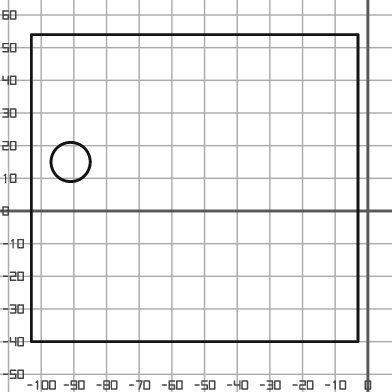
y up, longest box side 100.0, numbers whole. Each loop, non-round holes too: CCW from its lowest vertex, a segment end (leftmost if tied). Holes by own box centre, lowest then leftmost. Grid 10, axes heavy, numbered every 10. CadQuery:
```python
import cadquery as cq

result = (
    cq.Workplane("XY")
    .moveTo(-103.0, -40.0)
    .lineTo(-3.0, -40.0)
    .lineTo(-3.0, 54.0)
    .lineTo(-103.0, 54.0)
    .close()
    .moveTo(-91.0, 15.0)
    .circle(6.0)
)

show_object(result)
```